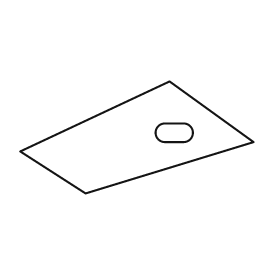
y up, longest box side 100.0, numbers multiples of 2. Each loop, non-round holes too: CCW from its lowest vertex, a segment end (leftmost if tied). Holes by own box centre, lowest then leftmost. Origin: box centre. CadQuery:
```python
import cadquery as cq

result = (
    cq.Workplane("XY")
    .moveTo(-22.0, -24.0)
    .lineTo(50.0, -2.0)
    .lineTo(14.0, 24.0)
    .lineTo(-50.0, -6.0)
    .close()
    .moveTo(12.0, -2.0)
    .lineTo(20.0, -2.0)
    .threePointArc((24.0, 2.0), (20.0, 6.0))
    .lineTo(12.0, 6.0)
    .threePointArc((8.0, 2.0), (12.0, -2.0))
    .close()
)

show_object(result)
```